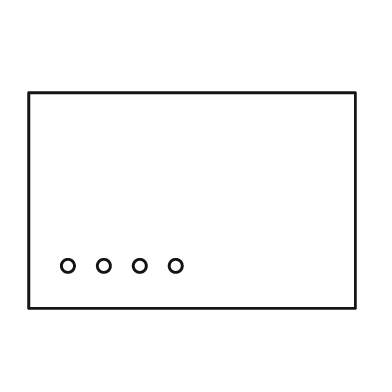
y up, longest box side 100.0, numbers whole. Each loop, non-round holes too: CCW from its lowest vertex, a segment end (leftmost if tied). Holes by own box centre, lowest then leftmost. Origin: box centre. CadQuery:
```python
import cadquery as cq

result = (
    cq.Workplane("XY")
    .moveTo(-50.0, -33.0)
    .lineTo(50.0, -33.0)
    .lineTo(50.0, 33.0)
    .lineTo(-50.0, 33.0)
    .close()
    .moveTo(-38.0, -20.0)
    .circle(2.0)
    .moveTo(-27.0, -20.0)
    .circle(2.0)
    .moveTo(-16.0, -20.0)
    .circle(2.0)
    .moveTo(-5.0, -20.0)
    .circle(2.0)
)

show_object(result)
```